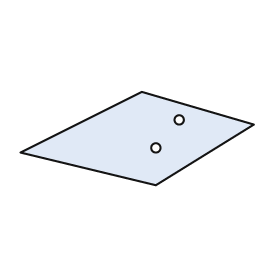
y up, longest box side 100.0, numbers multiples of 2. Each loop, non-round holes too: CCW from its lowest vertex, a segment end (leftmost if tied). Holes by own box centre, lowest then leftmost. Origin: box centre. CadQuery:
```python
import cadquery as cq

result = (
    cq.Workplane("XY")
    .moveTo(8.0, -20.0)
    .lineTo(50.0, 6.0)
    .lineTo(2.0, 20.0)
    .lineTo(-50.0, -6.0)
    .close()
    .moveTo(8.0, -4.0)
    .circle(2.0)
    .moveTo(18.0, 8.0)
    .circle(2.0)
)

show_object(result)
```